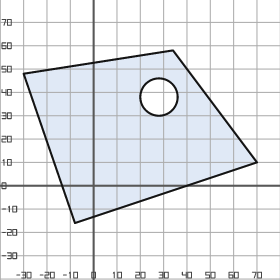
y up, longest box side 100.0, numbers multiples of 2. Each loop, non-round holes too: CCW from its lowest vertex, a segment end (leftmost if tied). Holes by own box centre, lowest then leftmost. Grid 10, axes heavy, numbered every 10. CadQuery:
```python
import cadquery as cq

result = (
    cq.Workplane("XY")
    .moveTo(-8.0, -16.0)
    .lineTo(70.0, 10.0)
    .lineTo(34.0, 58.0)
    .lineTo(-30.0, 48.0)
    .close()
    .moveTo(28.0, 38.0)
    .circle(8.0)
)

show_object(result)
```